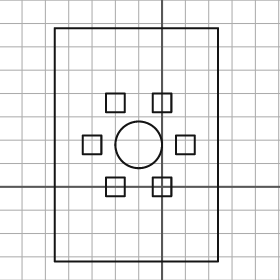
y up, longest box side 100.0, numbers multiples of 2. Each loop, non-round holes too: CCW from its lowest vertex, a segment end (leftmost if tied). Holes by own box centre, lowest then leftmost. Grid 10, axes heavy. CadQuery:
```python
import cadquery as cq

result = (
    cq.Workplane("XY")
    .moveTo(-46.0, -32.0)
    .lineTo(24.0, -32.0)
    .lineTo(24.0, 68.0)
    .lineTo(-46.0, 68.0)
    .close()
    .moveTo(-24.0, -4.0)
    .lineTo(-16.0, -4.0)
    .lineTo(-16.0, 4.0)
    .lineTo(-24.0, 4.0)
    .close()
    .moveTo(-4.0, -4.0)
    .lineTo(4.0, -4.0)
    .lineTo(4.0, 4.0)
    .lineTo(-4.0, 4.0)
    .close()
    .moveTo(-34.0, 14.0)
    .lineTo(-26.0, 14.0)
    .lineTo(-26.0, 22.0)
    .lineTo(-34.0, 22.0)
    .close()
    .moveTo(-10.0, 18.0)
    .circle(10.0)
    .moveTo(6.0, 14.0)
    .lineTo(14.0, 14.0)
    .lineTo(14.0, 22.0)
    .lineTo(6.0, 22.0)
    .close()
    .moveTo(-24.0, 32.0)
    .lineTo(-16.0, 32.0)
    .lineTo(-16.0, 40.0)
    .lineTo(-24.0, 40.0)
    .close()
    .moveTo(-4.0, 32.0)
    .lineTo(4.0, 32.0)
    .lineTo(4.0, 40.0)
    .lineTo(-4.0, 40.0)
    .close()
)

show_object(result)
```